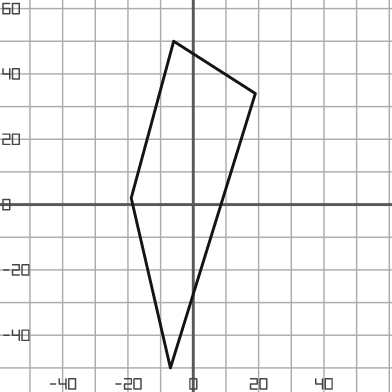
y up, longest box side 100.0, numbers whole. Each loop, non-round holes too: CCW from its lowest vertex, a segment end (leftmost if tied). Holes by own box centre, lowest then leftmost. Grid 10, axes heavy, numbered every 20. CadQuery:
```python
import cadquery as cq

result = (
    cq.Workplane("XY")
    .moveTo(-7.0, -50.0)
    .lineTo(19.0, 34.0)
    .lineTo(-6.0, 50.0)
    .lineTo(-19.0, 2.0)
    .close()
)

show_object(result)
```